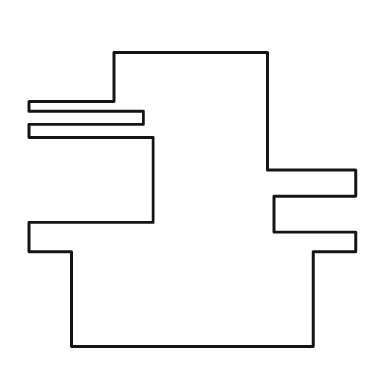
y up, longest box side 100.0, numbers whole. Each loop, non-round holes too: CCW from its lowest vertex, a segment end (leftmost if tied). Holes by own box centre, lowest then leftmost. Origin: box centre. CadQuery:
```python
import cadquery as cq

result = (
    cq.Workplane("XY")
    .moveTo(-37.0, -45.0)
    .lineTo(37.0, -45.0)
    .lineTo(37.0, -16.0)
    .lineTo(50.0, -16.0)
    .lineTo(50.0, -10.0)
    .lineTo(25.0, -10.0)
    .lineTo(25.0, 1.0)
    .lineTo(50.0, 1.0)
    .lineTo(50.0, 9.0)
    .lineTo(23.0, 9.0)
    .lineTo(23.0, 45.0)
    .lineTo(-24.0, 45.0)
    .lineTo(-24.0, 30.0)
    .lineTo(-50.0, 30.0)
    .lineTo(-50.0, 27.0)
    .lineTo(-15.0, 27.0)
    .lineTo(-15.0, 23.0)
    .lineTo(-50.0, 23.0)
    .lineTo(-50.0, 19.0)
    .lineTo(-12.0, 19.0)
    .lineTo(-12.0, -7.0)
    .lineTo(-50.0, -7.0)
    .lineTo(-50.0, -16.0)
    .lineTo(-37.0, -16.0)
    .close()
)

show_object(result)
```